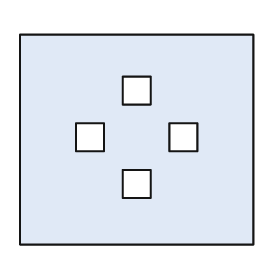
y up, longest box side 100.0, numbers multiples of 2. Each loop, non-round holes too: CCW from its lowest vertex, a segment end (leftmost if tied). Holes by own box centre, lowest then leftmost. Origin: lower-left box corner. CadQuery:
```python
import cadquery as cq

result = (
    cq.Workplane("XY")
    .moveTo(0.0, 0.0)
    .lineTo(100.0, 0.0)
    .lineTo(100.0, 90.0)
    .lineTo(0.0, 90.0)
    .close()
    .moveTo(44.0, 20.0)
    .lineTo(56.0, 20.0)
    .lineTo(56.0, 32.0)
    .lineTo(44.0, 32.0)
    .close()
    .moveTo(24.0, 40.0)
    .lineTo(36.0, 40.0)
    .lineTo(36.0, 52.0)
    .lineTo(24.0, 52.0)
    .close()
    .moveTo(64.0, 40.0)
    .lineTo(76.0, 40.0)
    .lineTo(76.0, 52.0)
    .lineTo(64.0, 52.0)
    .close()
    .moveTo(44.0, 60.0)
    .lineTo(56.0, 60.0)
    .lineTo(56.0, 72.0)
    .lineTo(44.0, 72.0)
    .close()
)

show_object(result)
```